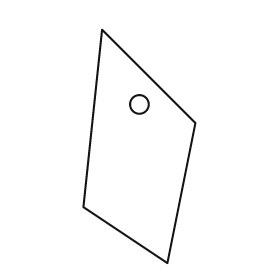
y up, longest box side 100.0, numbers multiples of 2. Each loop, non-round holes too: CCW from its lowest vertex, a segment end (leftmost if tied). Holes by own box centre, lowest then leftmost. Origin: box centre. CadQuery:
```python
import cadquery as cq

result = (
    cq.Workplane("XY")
    .moveTo(12.0, -50.0)
    .lineTo(24.0, 10.0)
    .lineTo(-16.0, 50.0)
    .lineTo(-24.0, -26.0)
    .close()
    .moveTo(0.0, 18.0)
    .circle(4.0)
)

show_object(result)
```